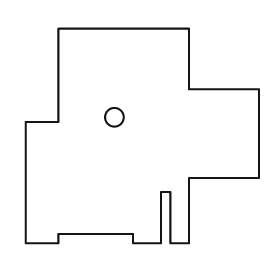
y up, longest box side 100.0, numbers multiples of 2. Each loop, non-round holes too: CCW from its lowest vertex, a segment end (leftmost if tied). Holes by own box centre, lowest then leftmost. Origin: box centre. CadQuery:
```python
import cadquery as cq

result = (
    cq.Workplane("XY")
    .moveTo(-50.0, -46.0)
    .lineTo(-36.0, -46.0)
    .lineTo(-36.0, -42.0)
    .lineTo(-4.0, -42.0)
    .lineTo(-4.0, -46.0)
    .lineTo(8.0, -46.0)
    .lineTo(8.0, -24.0)
    .lineTo(12.0, -24.0)
    .lineTo(12.0, -46.0)
    .lineTo(20.0, -46.0)
    .lineTo(20.0, -18.0)
    .lineTo(50.0, -18.0)
    .lineTo(50.0, 20.0)
    .lineTo(20.0, 20.0)
    .lineTo(20.0, 46.0)
    .lineTo(-36.0, 46.0)
    .lineTo(-36.0, 6.0)
    .lineTo(-50.0, 6.0)
    .close()
    .moveTo(-12.0, 8.0)
    .circle(4.0)
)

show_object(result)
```